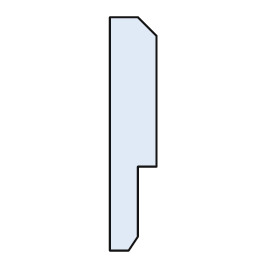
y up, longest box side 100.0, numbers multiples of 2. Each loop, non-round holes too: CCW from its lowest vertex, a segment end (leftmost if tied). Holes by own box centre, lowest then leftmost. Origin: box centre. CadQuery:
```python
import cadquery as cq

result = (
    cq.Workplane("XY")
    .moveTo(-10.0, -50.0)
    .lineTo(-2.0, -50.0)
    .lineTo(2.0, -44.0)
    .lineTo(2.0, -14.0)
    .lineTo(10.0, -14.0)
    .lineTo(10.0, 42.0)
    .lineTo(2.0, 50.0)
    .lineTo(-10.0, 50.0)
    .close()
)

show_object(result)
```